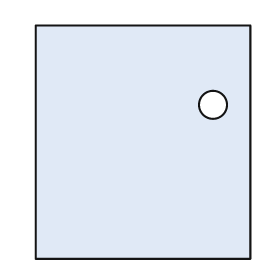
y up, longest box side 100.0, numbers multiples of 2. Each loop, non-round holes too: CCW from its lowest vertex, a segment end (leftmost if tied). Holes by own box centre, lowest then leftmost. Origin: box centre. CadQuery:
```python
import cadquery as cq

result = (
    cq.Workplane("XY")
    .moveTo(-46.0, -50.0)
    .lineTo(46.0, -50.0)
    .lineTo(46.0, 50.0)
    .lineTo(-46.0, 50.0)
    .close()
    .moveTo(30.0, 16.0)
    .circle(6.0)
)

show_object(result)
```